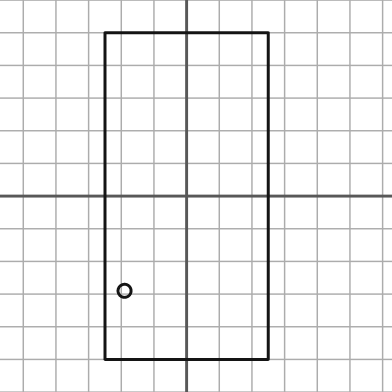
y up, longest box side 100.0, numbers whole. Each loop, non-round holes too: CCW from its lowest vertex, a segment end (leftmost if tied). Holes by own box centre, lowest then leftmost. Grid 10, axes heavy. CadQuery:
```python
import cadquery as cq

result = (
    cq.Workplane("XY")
    .moveTo(-25.0, -50.0)
    .lineTo(25.0, -50.0)
    .lineTo(25.0, 50.0)
    .lineTo(-25.0, 50.0)
    .close()
    .moveTo(-19.0, -29.0)
    .circle(2.0)
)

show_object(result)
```